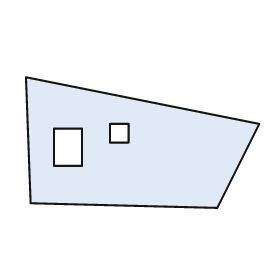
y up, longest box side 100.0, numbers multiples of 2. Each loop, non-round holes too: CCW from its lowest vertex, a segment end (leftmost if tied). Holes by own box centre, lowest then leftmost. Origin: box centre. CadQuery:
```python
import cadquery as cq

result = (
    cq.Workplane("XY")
    .moveTo(32.0, -28.0)
    .lineTo(50.0, 8.0)
    .lineTo(-50.0, 28.0)
    .lineTo(-48.0, -26.0)
    .close()
    .moveTo(-38.0, -10.0)
    .lineTo(-26.0, -10.0)
    .lineTo(-26.0, 6.0)
    .lineTo(-38.0, 6.0)
    .close()
    .moveTo(-14.0, 0.0)
    .lineTo(-6.0, 0.0)
    .lineTo(-6.0, 8.0)
    .lineTo(-14.0, 8.0)
    .close()
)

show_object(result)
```